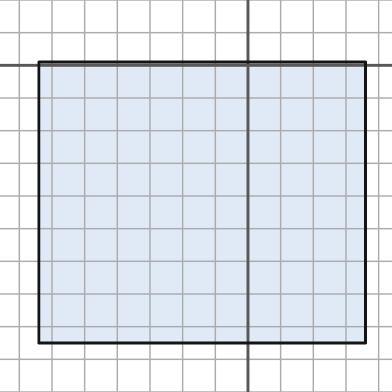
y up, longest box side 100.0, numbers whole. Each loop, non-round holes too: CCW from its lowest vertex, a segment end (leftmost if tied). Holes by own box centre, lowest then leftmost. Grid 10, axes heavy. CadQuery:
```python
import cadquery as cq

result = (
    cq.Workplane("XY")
    .moveTo(-64.0, -85.0)
    .lineTo(36.0, -85.0)
    .lineTo(36.0, 1.0)
    .lineTo(-64.0, 1.0)
    .close()
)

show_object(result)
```